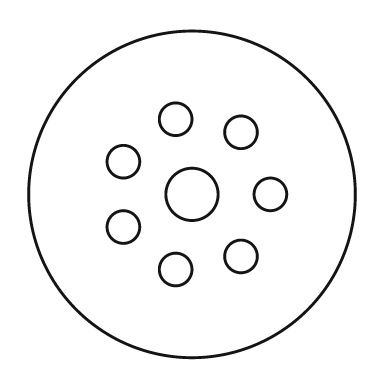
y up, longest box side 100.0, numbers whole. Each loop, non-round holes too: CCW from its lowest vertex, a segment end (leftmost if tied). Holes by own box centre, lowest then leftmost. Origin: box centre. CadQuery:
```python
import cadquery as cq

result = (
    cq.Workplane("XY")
    .moveTo(0.0, 0.0)
    .circle(50.0)
    .moveTo(-5.0, -23.0)
    .circle(5.0)
    .moveTo(15.0, -19.0)
    .circle(5.0)
    .moveTo(-21.0, -10.0)
    .circle(5.0)
    .moveTo(0.0, 0.0)
    .circle(8.0)
    .moveTo(24.0, 0.0)
    .circle(5.0)
    .moveTo(-21.0, 10.0)
    .circle(5.0)
    .moveTo(15.0, 19.0)
    .circle(5.0)
    .moveTo(-5.0, 23.0)
    .circle(5.0)
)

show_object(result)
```